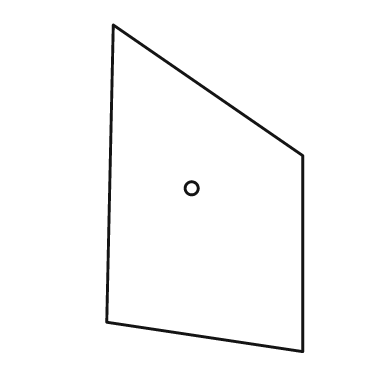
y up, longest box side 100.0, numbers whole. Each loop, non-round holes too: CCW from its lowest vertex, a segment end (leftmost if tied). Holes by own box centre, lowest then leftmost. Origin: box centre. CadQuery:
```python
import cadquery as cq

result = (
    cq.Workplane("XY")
    .moveTo(30.0, -50.0)
    .lineTo(30.0, 10.0)
    .lineTo(-28.0, 50.0)
    .lineTo(-30.0, -41.0)
    .close()
    .moveTo(-4.0, 0.0)
    .circle(2.0)
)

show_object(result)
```